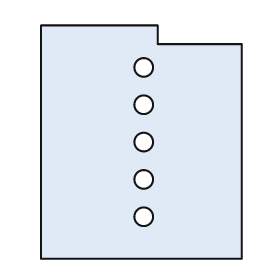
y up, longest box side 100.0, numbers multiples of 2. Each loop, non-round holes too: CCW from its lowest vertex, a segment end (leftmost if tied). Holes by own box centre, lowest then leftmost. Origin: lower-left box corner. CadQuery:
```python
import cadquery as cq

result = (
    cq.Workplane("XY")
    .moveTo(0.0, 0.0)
    .lineTo(86.0, 0.0)
    .lineTo(86.0, 92.0)
    .lineTo(50.0, 92.0)
    .lineTo(50.0, 100.0)
    .lineTo(0.0, 100.0)
    .close()
    .moveTo(44.0, 18.0)
    .circle(4.0)
    .moveTo(44.0, 34.0)
    .circle(4.0)
    .moveTo(44.0, 50.0)
    .circle(4.0)
    .moveTo(44.0, 66.0)
    .circle(4.0)
    .moveTo(44.0, 82.0)
    .circle(4.0)
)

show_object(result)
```